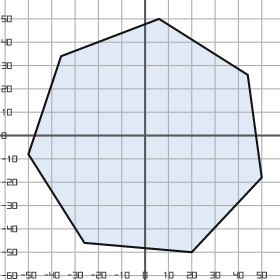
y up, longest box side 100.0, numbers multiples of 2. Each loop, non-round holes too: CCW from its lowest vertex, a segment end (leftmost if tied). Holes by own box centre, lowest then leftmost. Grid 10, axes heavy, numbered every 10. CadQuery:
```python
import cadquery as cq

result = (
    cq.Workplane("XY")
    .moveTo(20.0, -50.0)
    .lineTo(50.0, -18.0)
    .lineTo(44.0, 26.0)
    .lineTo(6.0, 50.0)
    .lineTo(-36.0, 34.0)
    .lineTo(-50.0, -8.0)
    .lineTo(-26.0, -46.0)
    .close()
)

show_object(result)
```